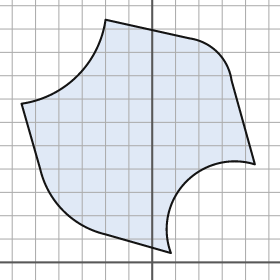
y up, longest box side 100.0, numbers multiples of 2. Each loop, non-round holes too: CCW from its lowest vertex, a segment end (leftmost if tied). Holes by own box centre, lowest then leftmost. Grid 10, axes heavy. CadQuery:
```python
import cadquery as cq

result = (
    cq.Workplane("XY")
    .moveTo(8.0, 4.0)
    .threePointArc((14.0, 34.0), (44.0, 42.0))
    .lineTo(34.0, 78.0)
    .threePointArc((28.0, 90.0), (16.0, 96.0))
    .lineTo(-20.0, 104.0)
    .threePointArc((-32.0, 80.0), (-56.0, 68.0))
    .lineTo(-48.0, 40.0)
    .threePointArc((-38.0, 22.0), (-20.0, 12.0))
    .close()
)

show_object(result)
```